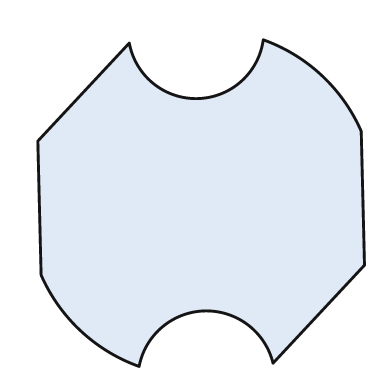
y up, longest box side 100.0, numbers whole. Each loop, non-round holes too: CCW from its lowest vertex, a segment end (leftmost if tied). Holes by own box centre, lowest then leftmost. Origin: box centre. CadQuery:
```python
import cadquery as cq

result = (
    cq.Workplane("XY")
    .moveTo(-19.0, -50.0)
    .threePointArc((1.0, -33.0), (22.0, -49.0))
    .lineTo(50.0, -19.0)
    .lineTo(49.0, 22.0)
    .threePointArc((37.0, 39.0), (19.0, 50.0))
    .threePointArc((-1.0, 32.0), (-22.0, 49.0))
    .lineTo(-50.0, 19.0)
    .lineTo(-49.0, -22.0)
    .threePointArc((-37.0, -39.0), (-19.0, -50.0))
    .close()
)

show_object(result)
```